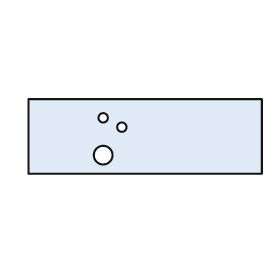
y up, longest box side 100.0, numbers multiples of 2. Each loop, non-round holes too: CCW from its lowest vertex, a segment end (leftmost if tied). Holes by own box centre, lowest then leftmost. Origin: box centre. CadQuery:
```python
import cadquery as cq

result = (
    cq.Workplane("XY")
    .moveTo(-50.0, -16.0)
    .lineTo(50.0, -16.0)
    .lineTo(50.0, 16.0)
    .lineTo(-50.0, 16.0)
    .close()
    .moveTo(-18.0, -8.0)
    .circle(4.0)
    .moveTo(-10.0, 4.0)
    .circle(2.0)
    .moveTo(-18.0, 8.0)
    .circle(2.0)
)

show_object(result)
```